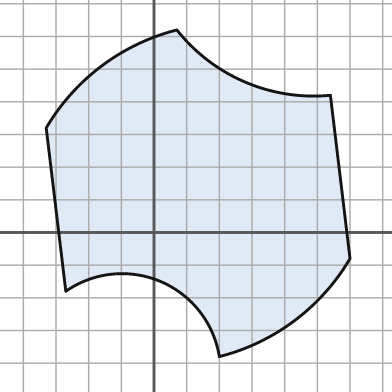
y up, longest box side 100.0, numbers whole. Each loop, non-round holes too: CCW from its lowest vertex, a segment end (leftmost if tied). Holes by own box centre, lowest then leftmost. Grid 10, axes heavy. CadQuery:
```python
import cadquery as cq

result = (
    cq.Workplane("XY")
    .moveTo(20.0, -38.0)
    .threePointArc((43.0, -27.0), (60.0, -8.0))
    .lineTo(54.0, 42.0)
    .threePointArc((28.0, 46.0), (7.0, 62.0))
    .threePointArc((-16.0, 51.0), (-33.0, 32.0))
    .lineTo(-27.0, -18.0)
    .threePointArc((2.0, -15.0), (20.0, -38.0))
    .close()
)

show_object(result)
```